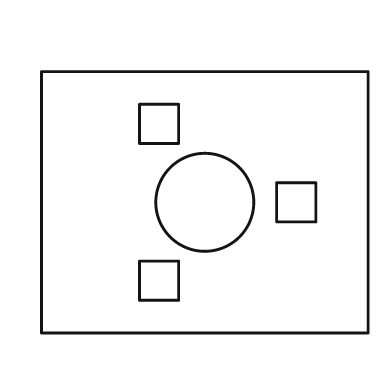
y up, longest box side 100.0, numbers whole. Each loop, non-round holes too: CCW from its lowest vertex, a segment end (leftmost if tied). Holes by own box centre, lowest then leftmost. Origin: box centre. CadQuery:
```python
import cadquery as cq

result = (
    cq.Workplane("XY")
    .moveTo(-50.0, -40.0)
    .lineTo(50.0, -40.0)
    .lineTo(50.0, 40.0)
    .lineTo(-50.0, 40.0)
    .close()
    .moveTo(-20.0, -30.0)
    .lineTo(-8.0, -30.0)
    .lineTo(-8.0, -18.0)
    .lineTo(-20.0, -18.0)
    .close()
    .moveTo(0.0, 0.0)
    .circle(15.0)
    .moveTo(22.0, -6.0)
    .lineTo(34.0, -6.0)
    .lineTo(34.0, 6.0)
    .lineTo(22.0, 6.0)
    .close()
    .moveTo(-20.0, 18.0)
    .lineTo(-8.0, 18.0)
    .lineTo(-8.0, 30.0)
    .lineTo(-20.0, 30.0)
    .close()
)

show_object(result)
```